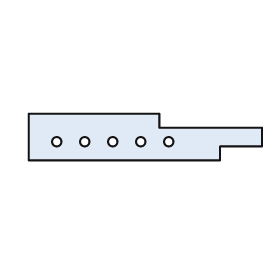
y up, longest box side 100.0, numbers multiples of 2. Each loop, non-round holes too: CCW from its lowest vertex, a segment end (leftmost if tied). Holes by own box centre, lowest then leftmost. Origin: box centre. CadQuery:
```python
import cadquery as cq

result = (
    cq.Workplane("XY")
    .moveTo(-50.0, -10.0)
    .lineTo(32.0, -10.0)
    .lineTo(32.0, -4.0)
    .lineTo(50.0, -4.0)
    .lineTo(50.0, 4.0)
    .lineTo(6.0, 4.0)
    .lineTo(6.0, 10.0)
    .lineTo(-50.0, 10.0)
    .close()
    .moveTo(-38.0, -2.0)
    .circle(2.0)
    .moveTo(-26.0, -2.0)
    .circle(2.0)
    .moveTo(-14.0, -2.0)
    .circle(2.0)
    .moveTo(-2.0, -2.0)
    .circle(2.0)
    .moveTo(10.0, -2.0)
    .circle(2.0)
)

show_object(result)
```